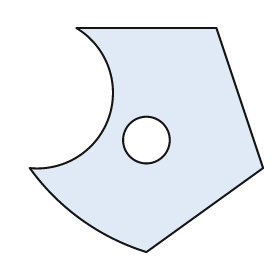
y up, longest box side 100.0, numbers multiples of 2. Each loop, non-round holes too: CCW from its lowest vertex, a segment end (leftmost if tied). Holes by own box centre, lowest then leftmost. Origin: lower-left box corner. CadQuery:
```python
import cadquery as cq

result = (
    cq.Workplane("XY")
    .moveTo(50.0, 0.0)
    .lineTo(100.0, 36.0)
    .lineTo(80.0, 96.0)
    .lineTo(20.0, 96.0)
    .threePointArc((34.0, 58.0), (0.0, 36.0))
    .threePointArc((22.0, 14.0), (50.0, 0.0))
    .close()
    .moveTo(50.0, 48.0)
    .circle(10.0)
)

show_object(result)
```